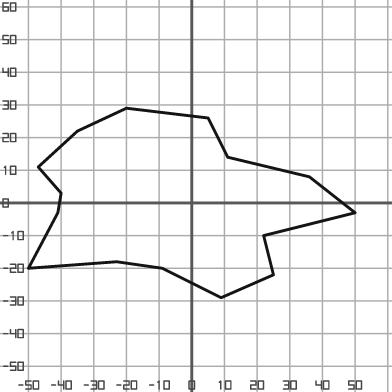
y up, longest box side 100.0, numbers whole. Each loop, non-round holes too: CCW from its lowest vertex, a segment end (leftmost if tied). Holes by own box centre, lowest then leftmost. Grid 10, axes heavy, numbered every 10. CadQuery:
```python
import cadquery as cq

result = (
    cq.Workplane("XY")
    .moveTo(9.0, -29.0)
    .lineTo(25.0, -22.0)
    .lineTo(22.0, -10.0)
    .lineTo(50.0, -3.0)
    .lineTo(36.0, 8.0)
    .lineTo(11.0, 14.0)
    .lineTo(5.0, 26.0)
    .lineTo(-20.0, 29.0)
    .lineTo(-35.0, 22.0)
    .lineTo(-47.0, 11.0)
    .lineTo(-40.0, 3.0)
    .lineTo(-41.0, -3.0)
    .lineTo(-50.0, -20.0)
    .lineTo(-23.0, -18.0)
    .lineTo(-9.0, -20.0)
    .close()
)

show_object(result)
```